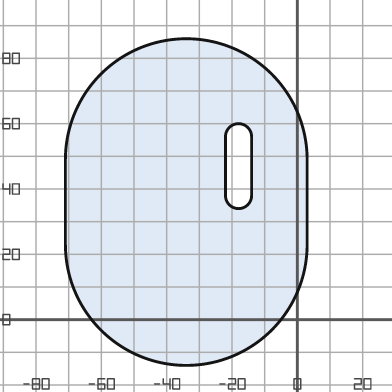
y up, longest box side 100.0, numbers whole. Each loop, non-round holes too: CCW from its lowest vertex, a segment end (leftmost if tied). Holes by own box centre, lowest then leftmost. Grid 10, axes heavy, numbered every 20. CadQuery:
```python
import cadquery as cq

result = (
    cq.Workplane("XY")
    .moveTo(-71.0, 23.0)
    .threePointArc((-34.0, -14.0), (3.0, 23.0))
    .lineTo(3.0, 49.0)
    .threePointArc((-34.0, 86.0), (-71.0, 49.0))
    .close()
    .moveTo(-22.0, 38.0)
    .threePointArc((-18.0, 34.0), (-14.0, 38.0))
    .lineTo(-14.0, 56.0)
    .threePointArc((-18.0, 60.0), (-22.0, 56.0))
    .close()
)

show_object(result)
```